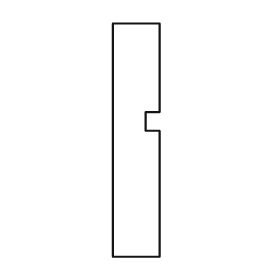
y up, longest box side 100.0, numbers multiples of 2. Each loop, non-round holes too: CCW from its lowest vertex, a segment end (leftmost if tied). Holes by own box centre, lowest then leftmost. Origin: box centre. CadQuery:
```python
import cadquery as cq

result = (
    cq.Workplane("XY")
    .moveTo(-10.0, -50.0)
    .lineTo(10.0, -50.0)
    .lineTo(10.0, 4.0)
    .lineTo(4.0, 4.0)
    .lineTo(4.0, 12.0)
    .lineTo(10.0, 12.0)
    .lineTo(10.0, 50.0)
    .lineTo(-10.0, 50.0)
    .close()
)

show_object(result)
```